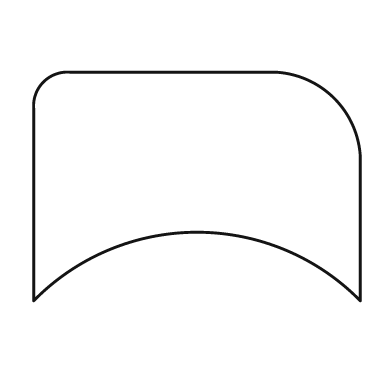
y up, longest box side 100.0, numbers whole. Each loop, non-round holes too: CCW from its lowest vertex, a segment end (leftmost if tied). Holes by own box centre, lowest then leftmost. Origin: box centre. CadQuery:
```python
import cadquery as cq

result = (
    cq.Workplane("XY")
    .moveTo(-50.0, -35.0)
    .threePointArc((0.0, -14.0), (50.0, -35.0))
    .lineTo(50.0, 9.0)
    .threePointArc((42.0, 27.0), (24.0, 35.0))
    .lineTo(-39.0, 35.0)
    .threePointArc((-47.0, 32.0), (-50.0, 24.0))
    .close()
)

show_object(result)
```